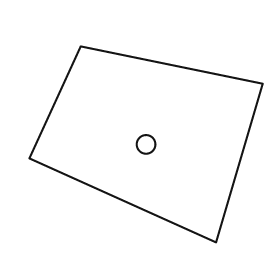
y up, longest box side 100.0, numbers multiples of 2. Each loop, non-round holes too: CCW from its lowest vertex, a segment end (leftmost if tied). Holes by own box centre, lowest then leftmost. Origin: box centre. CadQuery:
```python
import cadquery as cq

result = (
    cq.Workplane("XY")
    .moveTo(30.0, -42.0)
    .lineTo(50.0, 26.0)
    .lineTo(-28.0, 42.0)
    .lineTo(-50.0, -6.0)
    .close()
    .moveTo(0.0, 0.0)
    .circle(4.0)
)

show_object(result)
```